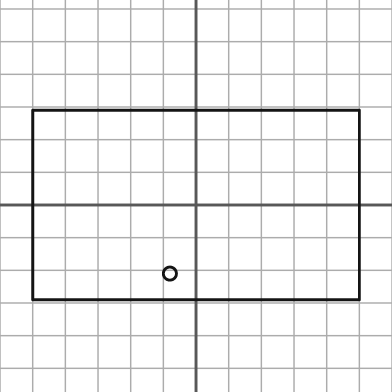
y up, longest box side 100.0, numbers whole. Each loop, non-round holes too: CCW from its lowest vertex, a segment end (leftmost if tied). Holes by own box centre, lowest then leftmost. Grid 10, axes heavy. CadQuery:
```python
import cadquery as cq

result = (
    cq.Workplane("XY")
    .moveTo(-50.0, -29.0)
    .lineTo(50.0, -29.0)
    .lineTo(50.0, 29.0)
    .lineTo(-50.0, 29.0)
    .close()
    .moveTo(-8.0, -21.0)
    .circle(2.0)
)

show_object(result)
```